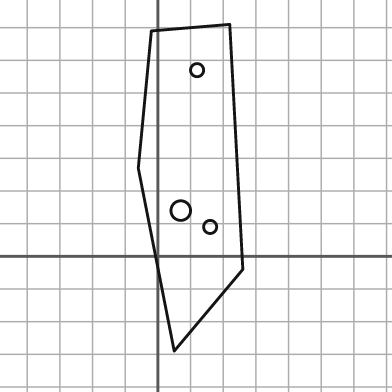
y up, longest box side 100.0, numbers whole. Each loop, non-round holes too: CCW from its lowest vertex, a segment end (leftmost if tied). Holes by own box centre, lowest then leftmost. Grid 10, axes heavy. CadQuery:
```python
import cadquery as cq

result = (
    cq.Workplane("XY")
    .moveTo(5.0, -29.0)
    .lineTo(26.0, -4.0)
    .lineTo(22.0, 71.0)
    .lineTo(-2.0, 69.0)
    .lineTo(-6.0, 27.0)
    .close()
    .moveTo(16.0, 9.0)
    .circle(2.0)
    .moveTo(7.0, 14.0)
    .circle(3.0)
    .moveTo(12.0, 57.0)
    .circle(2.0)
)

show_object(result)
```